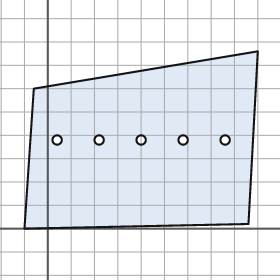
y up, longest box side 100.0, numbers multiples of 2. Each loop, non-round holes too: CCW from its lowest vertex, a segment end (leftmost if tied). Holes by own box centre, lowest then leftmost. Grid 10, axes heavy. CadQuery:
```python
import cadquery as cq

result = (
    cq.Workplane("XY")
    .moveTo(-10.0, 0.0)
    .lineTo(86.0, 2.0)
    .lineTo(90.0, 76.0)
    .lineTo(-6.0, 60.0)
    .close()
    .moveTo(4.0, 38.0)
    .circle(2.0)
    .moveTo(22.0, 38.0)
    .circle(2.0)
    .moveTo(40.0, 38.0)
    .circle(2.0)
    .moveTo(58.0, 38.0)
    .circle(2.0)
    .moveTo(76.0, 38.0)
    .circle(2.0)
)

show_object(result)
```